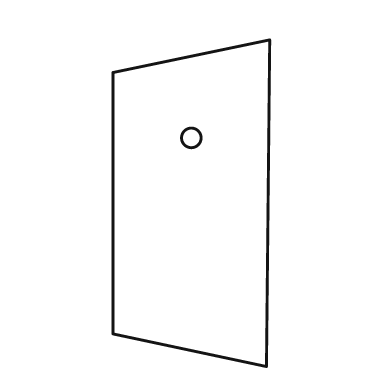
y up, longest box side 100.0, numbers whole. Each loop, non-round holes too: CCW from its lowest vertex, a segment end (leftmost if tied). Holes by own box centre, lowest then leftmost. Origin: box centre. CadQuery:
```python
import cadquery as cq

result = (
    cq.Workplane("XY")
    .moveTo(23.0, -50.0)
    .lineTo(24.0, 50.0)
    .lineTo(-24.0, 40.0)
    .lineTo(-24.0, -40.0)
    .close()
    .moveTo(0.0, 20.0)
    .circle(3.0)
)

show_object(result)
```